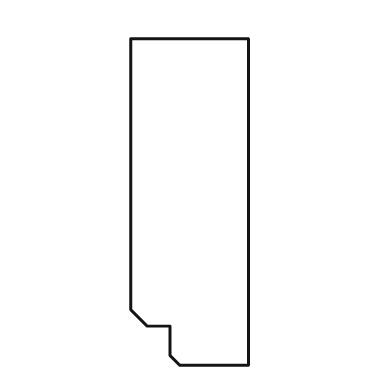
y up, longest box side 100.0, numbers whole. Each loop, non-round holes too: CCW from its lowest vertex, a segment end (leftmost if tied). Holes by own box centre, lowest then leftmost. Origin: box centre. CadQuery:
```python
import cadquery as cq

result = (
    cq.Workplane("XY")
    .moveTo(-3.0, -50.0)
    .lineTo(18.0, -50.0)
    .lineTo(18.0, 50.0)
    .lineTo(-18.0, 50.0)
    .lineTo(-18.0, -33.0)
    .lineTo(-13.0, -38.0)
    .lineTo(-6.0, -38.0)
    .lineTo(-6.0, -47.0)
    .close()
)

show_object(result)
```